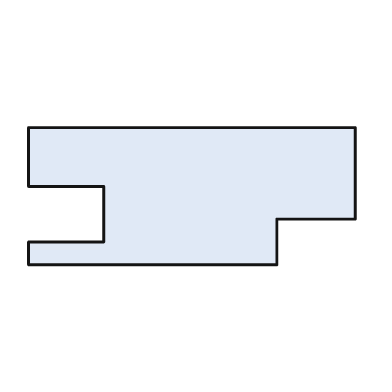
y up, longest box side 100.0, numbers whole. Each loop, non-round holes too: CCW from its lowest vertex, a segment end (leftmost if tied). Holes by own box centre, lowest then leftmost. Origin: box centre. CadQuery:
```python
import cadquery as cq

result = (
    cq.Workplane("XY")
    .moveTo(-50.0, -21.0)
    .lineTo(26.0, -21.0)
    .lineTo(26.0, -7.0)
    .lineTo(50.0, -7.0)
    .lineTo(50.0, 21.0)
    .lineTo(-50.0, 21.0)
    .lineTo(-50.0, 3.0)
    .lineTo(-27.0, 3.0)
    .lineTo(-27.0, -14.0)
    .lineTo(-50.0, -14.0)
    .close()
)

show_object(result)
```